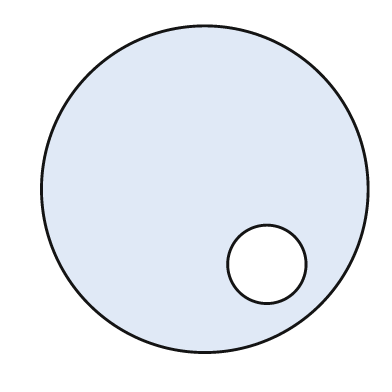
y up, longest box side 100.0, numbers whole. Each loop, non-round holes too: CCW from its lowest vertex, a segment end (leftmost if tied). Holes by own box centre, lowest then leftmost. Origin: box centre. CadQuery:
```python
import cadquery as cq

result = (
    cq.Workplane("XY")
    .moveTo(0.0, 0.0)
    .circle(50.0)
    .moveTo(19.0, -23.0)
    .circle(12.0)
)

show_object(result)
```